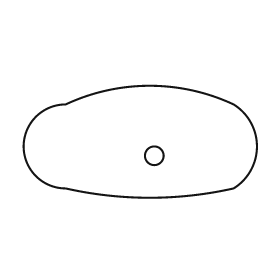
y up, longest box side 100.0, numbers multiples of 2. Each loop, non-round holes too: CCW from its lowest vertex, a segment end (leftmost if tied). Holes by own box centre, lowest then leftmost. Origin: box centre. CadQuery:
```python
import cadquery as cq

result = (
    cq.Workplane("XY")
    .moveTo(-32.0, -20.0)
    .threePointArc((4.0, -24.0), (40.0, -20.0))
    .threePointArc((50.0, -2.0), (40.0, 16.0))
    .threePointArc((4.0, 24.0), (-32.0, 16.0))
    .threePointArc((-50.0, -2.0), (-32.0, -20.0))
    .close()
    .moveTo(6.0, -6.0)
    .circle(4.0)
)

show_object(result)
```